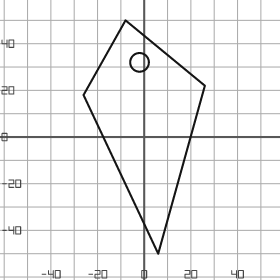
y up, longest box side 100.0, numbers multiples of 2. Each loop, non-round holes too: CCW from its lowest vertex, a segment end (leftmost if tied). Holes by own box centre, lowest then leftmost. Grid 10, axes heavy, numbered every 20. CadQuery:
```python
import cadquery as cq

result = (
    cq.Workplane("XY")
    .moveTo(6.0, -50.0)
    .lineTo(26.0, 22.0)
    .lineTo(-8.0, 50.0)
    .lineTo(-26.0, 18.0)
    .close()
    .moveTo(-2.0, 32.0)
    .circle(4.0)
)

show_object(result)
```